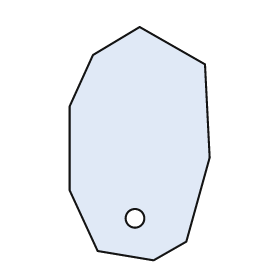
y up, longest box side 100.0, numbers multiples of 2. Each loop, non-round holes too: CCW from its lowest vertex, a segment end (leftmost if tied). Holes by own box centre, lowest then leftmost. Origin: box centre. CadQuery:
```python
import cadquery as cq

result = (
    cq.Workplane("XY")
    .moveTo(6.0, -50.0)
    .lineTo(20.0, -42.0)
    .lineTo(30.0, -6.0)
    .lineTo(28.0, 34.0)
    .lineTo(0.0, 50.0)
    .lineTo(-20.0, 38.0)
    .lineTo(-30.0, 16.0)
    .lineTo(-30.0, -20.0)
    .lineTo(-18.0, -46.0)
    .close()
    .moveTo(-2.0, -32.0)
    .circle(4.0)
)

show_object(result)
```